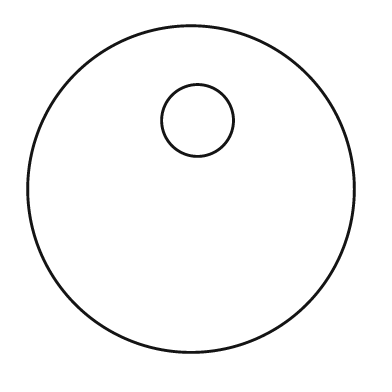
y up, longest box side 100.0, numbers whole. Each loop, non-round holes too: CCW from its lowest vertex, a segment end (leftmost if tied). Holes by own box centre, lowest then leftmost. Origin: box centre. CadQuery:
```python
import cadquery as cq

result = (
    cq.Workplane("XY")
    .moveTo(0.0, 0.0)
    .circle(50.0)
    .moveTo(2.0, 21.0)
    .circle(11.0)
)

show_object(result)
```